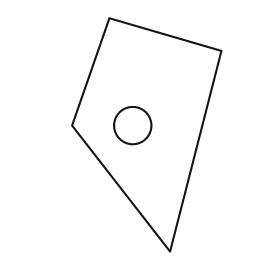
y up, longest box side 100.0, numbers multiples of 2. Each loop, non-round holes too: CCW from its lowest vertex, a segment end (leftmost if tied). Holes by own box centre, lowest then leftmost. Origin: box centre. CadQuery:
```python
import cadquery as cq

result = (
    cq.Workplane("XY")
    .moveTo(10.0, -50.0)
    .lineTo(32.0, 36.0)
    .lineTo(-16.0, 50.0)
    .lineTo(-32.0, 4.0)
    .close()
    .moveTo(-6.0, 4.0)
    .circle(8.0)
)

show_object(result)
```